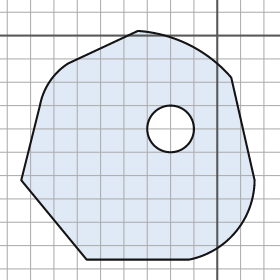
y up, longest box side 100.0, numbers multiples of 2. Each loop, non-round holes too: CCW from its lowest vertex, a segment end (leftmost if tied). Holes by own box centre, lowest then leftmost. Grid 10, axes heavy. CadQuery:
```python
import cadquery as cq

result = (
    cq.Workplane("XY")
    .moveTo(-56.0, -96.0)
    .lineTo(-12.0, -96.0)
    .threePointArc((8.0, -84.0), (16.0, -62.0))
    .lineTo(6.0, -18.0)
    .threePointArc((-12.0, -4.0), (-34.0, 2.0))
    .lineTo(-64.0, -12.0)
    .threePointArc((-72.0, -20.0), (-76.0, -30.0))
    .lineTo(-84.0, -62.0)
    .close()
    .moveTo(-20.0, -40.0)
    .circle(10.0)
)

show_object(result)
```